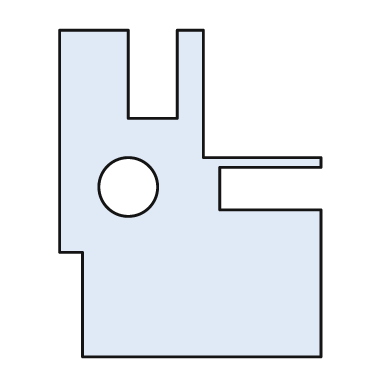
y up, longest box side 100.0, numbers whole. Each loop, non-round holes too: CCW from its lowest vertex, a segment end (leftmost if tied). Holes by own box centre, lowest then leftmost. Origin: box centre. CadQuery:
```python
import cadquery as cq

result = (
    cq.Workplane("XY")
    .moveTo(-33.0, -50.0)
    .lineTo(40.0, -50.0)
    .lineTo(40.0, -5.0)
    .lineTo(9.0, -5.0)
    .lineTo(9.0, 8.0)
    .lineTo(40.0, 8.0)
    .lineTo(40.0, 11.0)
    .lineTo(4.0, 11.0)
    .lineTo(4.0, 50.0)
    .lineTo(-4.0, 50.0)
    .lineTo(-4.0, 23.0)
    .lineTo(-19.0, 23.0)
    .lineTo(-19.0, 50.0)
    .lineTo(-40.0, 50.0)
    .lineTo(-40.0, -18.0)
    .lineTo(-33.0, -18.0)
    .close()
    .moveTo(-19.0, 2.0)
    .circle(9.0)
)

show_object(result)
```